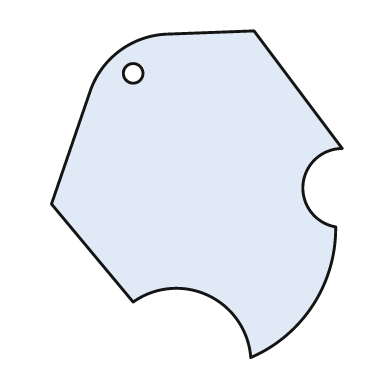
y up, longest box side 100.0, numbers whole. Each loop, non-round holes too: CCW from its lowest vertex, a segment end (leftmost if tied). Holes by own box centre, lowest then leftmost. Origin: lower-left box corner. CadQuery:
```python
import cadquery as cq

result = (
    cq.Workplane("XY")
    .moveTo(61.0, 0.0)
    .threePointArc((80.0, 16.0), (87.0, 40.0))
    .threePointArc((77.0, 53.0), (89.0, 64.0))
    .lineTo(62.0, 100.0)
    .lineTo(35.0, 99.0)
    .threePointArc((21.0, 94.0), (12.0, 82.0))
    .lineTo(0.0, 47.0)
    .lineTo(25.0, 17.0)
    .threePointArc((48.0, 19.0), (61.0, 0.0))
    .close()
    .moveTo(25.0, 87.0)
    .circle(3.0)
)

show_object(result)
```